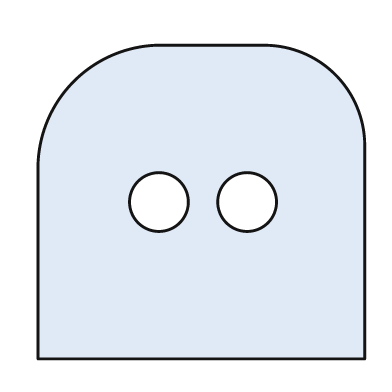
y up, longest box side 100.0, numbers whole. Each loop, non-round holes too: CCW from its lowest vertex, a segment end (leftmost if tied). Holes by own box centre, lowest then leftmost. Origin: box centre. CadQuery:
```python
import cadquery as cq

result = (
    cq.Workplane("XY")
    .moveTo(-50.0, -48.0)
    .lineTo(50.0, -48.0)
    .lineTo(50.0, 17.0)
    .threePointArc((41.0, 39.0), (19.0, 48.0))
    .lineTo(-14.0, 48.0)
    .threePointArc((-39.0, 37.0), (-50.0, 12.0))
    .close()
    .moveTo(-13.0, 0.0)
    .circle(9.0)
    .moveTo(14.0, 0.0)
    .circle(9.0)
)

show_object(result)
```